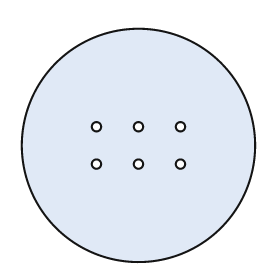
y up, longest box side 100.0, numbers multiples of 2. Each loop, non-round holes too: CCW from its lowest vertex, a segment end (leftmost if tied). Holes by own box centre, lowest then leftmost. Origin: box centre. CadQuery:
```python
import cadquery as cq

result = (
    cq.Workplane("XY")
    .moveTo(0.0, 0.0)
    .circle(50.0)
    .moveTo(-18.0, -8.0)
    .circle(2.0)
    .moveTo(0.0, -8.0)
    .circle(2.0)
    .moveTo(18.0, -8.0)
    .circle(2.0)
    .moveTo(-18.0, 8.0)
    .circle(2.0)
    .moveTo(0.0, 8.0)
    .circle(2.0)
    .moveTo(18.0, 8.0)
    .circle(2.0)
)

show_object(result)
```